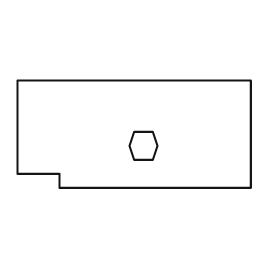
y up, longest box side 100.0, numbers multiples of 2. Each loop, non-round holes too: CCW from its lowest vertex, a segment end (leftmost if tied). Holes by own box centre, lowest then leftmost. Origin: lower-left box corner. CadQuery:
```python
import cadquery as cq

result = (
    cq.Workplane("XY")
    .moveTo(18.0, 0.0)
    .lineTo(100.0, 0.0)
    .lineTo(100.0, 46.0)
    .lineTo(0.0, 46.0)
    .lineTo(0.0, 6.0)
    .lineTo(18.0, 6.0)
    .close()
    .moveTo(50.0, 12.0)
    .lineTo(58.0, 12.0)
    .lineTo(60.0, 18.0)
    .lineTo(58.0, 24.0)
    .lineTo(50.0, 24.0)
    .lineTo(48.0, 18.0)
    .close()
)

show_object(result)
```